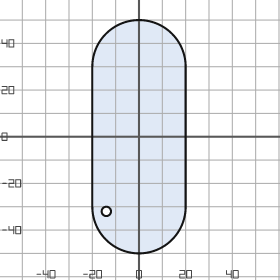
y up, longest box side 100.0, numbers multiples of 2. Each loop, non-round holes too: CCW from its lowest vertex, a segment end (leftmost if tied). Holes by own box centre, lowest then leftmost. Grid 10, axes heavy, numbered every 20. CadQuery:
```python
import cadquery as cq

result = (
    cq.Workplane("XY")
    .moveTo(-20.0, -30.0)
    .threePointArc((0.0, -50.0), (20.0, -30.0))
    .lineTo(20.0, 30.0)
    .threePointArc((0.0, 50.0), (-20.0, 30.0))
    .close()
    .moveTo(-14.0, -32.0)
    .circle(2.0)
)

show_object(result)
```